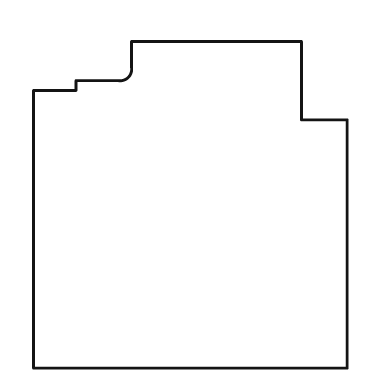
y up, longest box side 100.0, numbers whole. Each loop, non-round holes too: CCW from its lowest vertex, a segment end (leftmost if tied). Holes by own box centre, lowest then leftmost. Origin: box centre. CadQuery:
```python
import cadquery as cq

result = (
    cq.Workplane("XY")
    .moveTo(-48.0, -50.0)
    .lineTo(48.0, -50.0)
    .lineTo(48.0, 26.0)
    .lineTo(34.0, 26.0)
    .lineTo(34.0, 50.0)
    .lineTo(-18.0, 50.0)
    .lineTo(-18.0, 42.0)
    .threePointArc((-19.0, 39.0), (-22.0, 38.0))
    .lineTo(-35.0, 38.0)
    .lineTo(-35.0, 35.0)
    .lineTo(-48.0, 35.0)
    .close()
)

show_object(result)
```